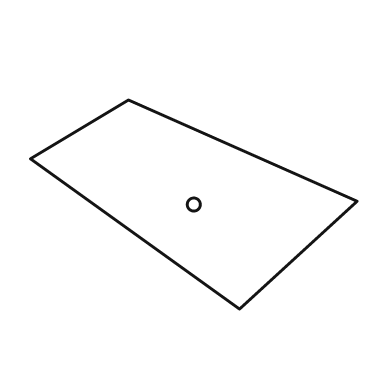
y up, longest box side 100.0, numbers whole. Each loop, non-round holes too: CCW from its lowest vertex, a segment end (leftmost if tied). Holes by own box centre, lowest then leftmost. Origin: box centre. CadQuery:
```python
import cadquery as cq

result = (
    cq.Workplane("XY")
    .moveTo(14.0, -32.0)
    .lineTo(50.0, 1.0)
    .lineTo(-20.0, 32.0)
    .lineTo(-50.0, 14.0)
    .close()
    .moveTo(0.0, 0.0)
    .circle(2.0)
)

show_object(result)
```